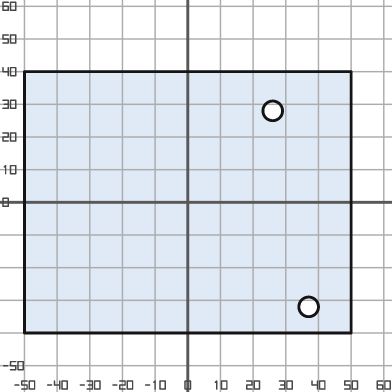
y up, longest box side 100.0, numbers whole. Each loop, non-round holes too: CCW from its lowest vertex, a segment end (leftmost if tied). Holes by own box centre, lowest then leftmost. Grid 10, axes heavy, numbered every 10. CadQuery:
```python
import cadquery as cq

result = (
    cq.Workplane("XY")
    .moveTo(-50.0, -40.0)
    .lineTo(50.0, -40.0)
    .lineTo(50.0, 40.0)
    .lineTo(-50.0, 40.0)
    .close()
    .moveTo(37.0, -32.0)
    .circle(3.0)
    .moveTo(26.0, 28.0)
    .circle(3.0)
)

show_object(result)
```